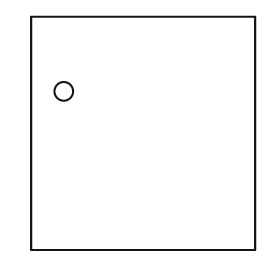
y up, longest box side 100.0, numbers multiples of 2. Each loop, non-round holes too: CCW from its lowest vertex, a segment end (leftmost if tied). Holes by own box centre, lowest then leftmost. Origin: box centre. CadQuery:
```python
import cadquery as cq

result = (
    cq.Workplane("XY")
    .moveTo(-48.0, -50.0)
    .lineTo(48.0, -50.0)
    .lineTo(48.0, 50.0)
    .lineTo(-48.0, 50.0)
    .close()
    .moveTo(-34.0, 18.0)
    .circle(4.0)
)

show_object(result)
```